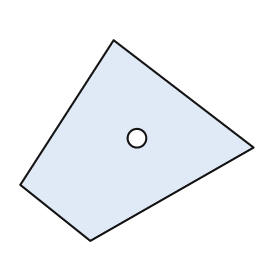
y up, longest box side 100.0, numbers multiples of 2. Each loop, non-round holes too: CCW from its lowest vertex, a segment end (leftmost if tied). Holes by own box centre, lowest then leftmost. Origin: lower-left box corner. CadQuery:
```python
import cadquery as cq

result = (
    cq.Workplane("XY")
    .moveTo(30.0, 0.0)
    .lineTo(100.0, 40.0)
    .lineTo(40.0, 86.0)
    .lineTo(0.0, 24.0)
    .close()
    .moveTo(50.0, 44.0)
    .circle(4.0)
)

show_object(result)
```